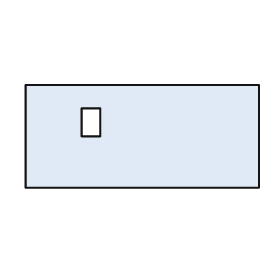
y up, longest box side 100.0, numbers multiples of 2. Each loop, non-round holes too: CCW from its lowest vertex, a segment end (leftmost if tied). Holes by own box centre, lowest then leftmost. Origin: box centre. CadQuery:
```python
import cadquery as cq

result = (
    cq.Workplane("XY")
    .moveTo(-50.0, -22.0)
    .lineTo(50.0, -22.0)
    .lineTo(50.0, 22.0)
    .lineTo(-50.0, 22.0)
    .close()
    .moveTo(-26.0, 0.0)
    .lineTo(-18.0, 0.0)
    .lineTo(-18.0, 12.0)
    .lineTo(-26.0, 12.0)
    .close()
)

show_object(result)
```